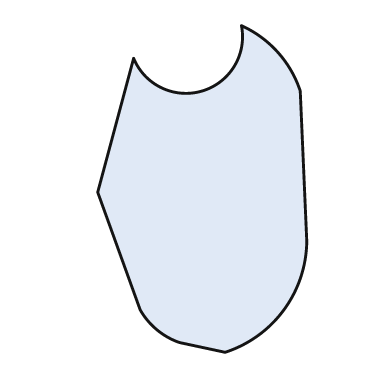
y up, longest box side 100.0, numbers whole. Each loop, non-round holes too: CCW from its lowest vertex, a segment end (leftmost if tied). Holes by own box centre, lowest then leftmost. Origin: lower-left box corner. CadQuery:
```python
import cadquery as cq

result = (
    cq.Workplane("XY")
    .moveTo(39.0, 0.0)
    .threePointArc((57.0, 13.0), (64.0, 34.0))
    .lineTo(62.0, 80.0)
    .threePointArc((55.0, 92.0), (44.0, 100.0))
    .threePointArc((32.0, 80.0), (11.0, 90.0))
    .lineTo(0.0, 49.0)
    .lineTo(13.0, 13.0)
    .threePointArc((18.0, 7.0), (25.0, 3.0))
    .close()
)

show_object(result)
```